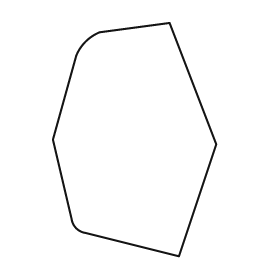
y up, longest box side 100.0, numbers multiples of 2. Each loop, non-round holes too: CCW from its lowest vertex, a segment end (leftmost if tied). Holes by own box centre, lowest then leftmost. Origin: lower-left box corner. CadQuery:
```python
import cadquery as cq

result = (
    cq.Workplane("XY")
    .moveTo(54.0, 0.0)
    .lineTo(70.0, 48.0)
    .lineTo(50.0, 100.0)
    .lineTo(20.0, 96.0)
    .threePointArc((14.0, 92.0), (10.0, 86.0))
    .lineTo(0.0, 50.0)
    .lineTo(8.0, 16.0)
    .threePointArc((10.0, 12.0), (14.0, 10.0))
    .close()
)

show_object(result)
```